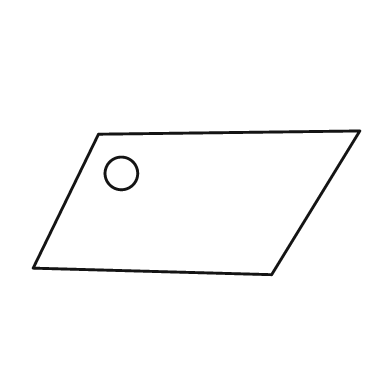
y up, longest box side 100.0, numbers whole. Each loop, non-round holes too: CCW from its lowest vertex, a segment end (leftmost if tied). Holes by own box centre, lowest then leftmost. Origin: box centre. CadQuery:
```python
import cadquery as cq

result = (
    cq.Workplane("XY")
    .moveTo(23.0, -22.0)
    .lineTo(50.0, 22.0)
    .lineTo(-30.0, 21.0)
    .lineTo(-50.0, -20.0)
    .close()
    .moveTo(-23.0, 9.0)
    .circle(5.0)
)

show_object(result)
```